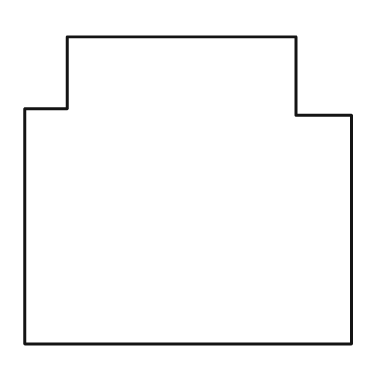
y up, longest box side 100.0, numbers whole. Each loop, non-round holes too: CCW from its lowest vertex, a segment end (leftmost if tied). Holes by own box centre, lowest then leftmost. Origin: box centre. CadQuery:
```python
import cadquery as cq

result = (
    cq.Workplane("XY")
    .moveTo(-50.0, -47.0)
    .lineTo(50.0, -47.0)
    .lineTo(50.0, 23.0)
    .lineTo(33.0, 23.0)
    .lineTo(33.0, 47.0)
    .lineTo(-37.0, 47.0)
    .lineTo(-37.0, 25.0)
    .lineTo(-50.0, 25.0)
    .close()
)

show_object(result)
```